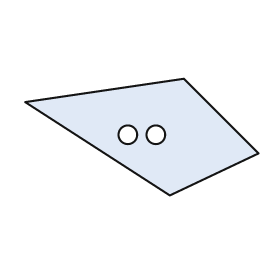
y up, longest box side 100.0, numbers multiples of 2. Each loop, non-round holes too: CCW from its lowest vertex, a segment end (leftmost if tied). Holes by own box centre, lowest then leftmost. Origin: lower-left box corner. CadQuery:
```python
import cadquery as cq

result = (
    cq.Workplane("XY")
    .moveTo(62.0, 0.0)
    .lineTo(100.0, 18.0)
    .lineTo(68.0, 50.0)
    .lineTo(0.0, 40.0)
    .close()
    .moveTo(44.0, 26.0)
    .circle(4.0)
    .moveTo(56.0, 26.0)
    .circle(4.0)
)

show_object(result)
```